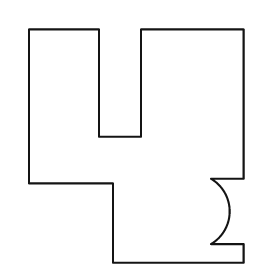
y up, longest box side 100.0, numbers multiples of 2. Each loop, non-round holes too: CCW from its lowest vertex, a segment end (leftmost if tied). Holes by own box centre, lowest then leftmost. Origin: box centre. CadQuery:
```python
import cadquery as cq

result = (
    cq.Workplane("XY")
    .moveTo(-10.0, -50.0)
    .lineTo(46.0, -50.0)
    .lineTo(46.0, -42.0)
    .lineTo(32.0, -42.0)
    .threePointArc((40.0, -28.0), (32.0, -14.0))
    .lineTo(46.0, -14.0)
    .lineTo(46.0, 50.0)
    .lineTo(2.0, 50.0)
    .lineTo(2.0, 4.0)
    .lineTo(-16.0, 4.0)
    .lineTo(-16.0, 50.0)
    .lineTo(-46.0, 50.0)
    .lineTo(-46.0, -16.0)
    .lineTo(-10.0, -16.0)
    .close()
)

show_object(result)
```